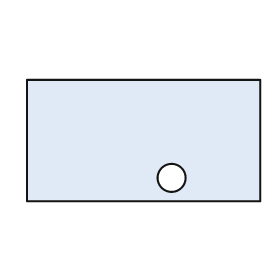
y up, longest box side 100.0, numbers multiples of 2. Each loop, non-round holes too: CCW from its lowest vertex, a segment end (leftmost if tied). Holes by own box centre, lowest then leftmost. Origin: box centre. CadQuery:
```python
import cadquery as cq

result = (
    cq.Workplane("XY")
    .moveTo(-50.0, -26.0)
    .lineTo(50.0, -26.0)
    .lineTo(50.0, 26.0)
    .lineTo(-50.0, 26.0)
    .close()
    .moveTo(12.0, -16.0)
    .circle(6.0)
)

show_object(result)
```